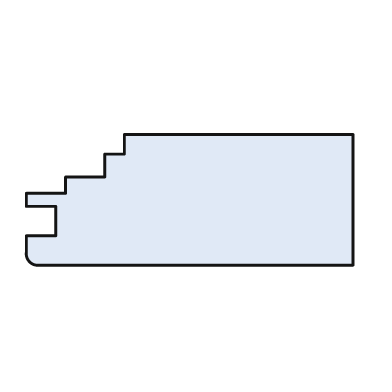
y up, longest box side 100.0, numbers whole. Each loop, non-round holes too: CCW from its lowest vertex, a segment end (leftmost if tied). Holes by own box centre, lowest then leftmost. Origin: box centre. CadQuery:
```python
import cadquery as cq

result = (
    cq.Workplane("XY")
    .moveTo(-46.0, -20.0)
    .lineTo(50.0, -20.0)
    .lineTo(50.0, 20.0)
    .lineTo(-20.0, 20.0)
    .lineTo(-20.0, 14.0)
    .lineTo(-26.0, 14.0)
    .lineTo(-26.0, 7.0)
    .lineTo(-38.0, 7.0)
    .lineTo(-38.0, 2.0)
    .lineTo(-50.0, 2.0)
    .lineTo(-50.0, -2.0)
    .lineTo(-41.0, -2.0)
    .lineTo(-41.0, -11.0)
    .lineTo(-50.0, -11.0)
    .lineTo(-50.0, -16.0)
    .threePointArc((-49.0, -19.0), (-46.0, -20.0))
    .close()
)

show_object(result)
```